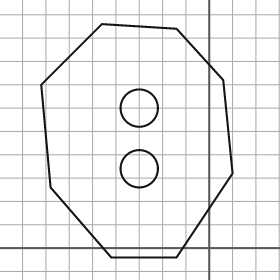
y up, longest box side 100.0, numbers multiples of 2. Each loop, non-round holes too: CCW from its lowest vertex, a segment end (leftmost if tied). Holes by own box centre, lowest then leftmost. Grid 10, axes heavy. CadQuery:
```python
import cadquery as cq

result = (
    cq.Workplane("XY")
    .moveTo(-42.0, -4.0)
    .lineTo(-14.0, -4.0)
    .lineTo(10.0, 32.0)
    .lineTo(6.0, 72.0)
    .lineTo(-14.0, 94.0)
    .lineTo(-46.0, 96.0)
    .lineTo(-72.0, 70.0)
    .lineTo(-68.0, 26.0)
    .close()
    .moveTo(-30.0, 34.0)
    .circle(8.0)
    .moveTo(-30.0, 60.0)
    .circle(8.0)
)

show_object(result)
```